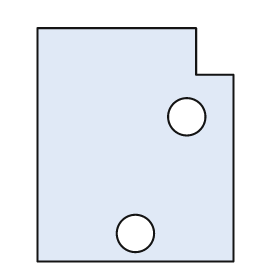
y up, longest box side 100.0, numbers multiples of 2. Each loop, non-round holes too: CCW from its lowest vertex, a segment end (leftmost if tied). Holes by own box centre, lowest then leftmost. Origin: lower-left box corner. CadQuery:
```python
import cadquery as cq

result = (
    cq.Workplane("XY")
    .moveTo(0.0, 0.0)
    .lineTo(84.0, 0.0)
    .lineTo(84.0, 80.0)
    .lineTo(68.0, 80.0)
    .lineTo(68.0, 100.0)
    .lineTo(0.0, 100.0)
    .close()
    .moveTo(42.0, 12.0)
    .circle(8.0)
    .moveTo(64.0, 62.0)
    .circle(8.0)
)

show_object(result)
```